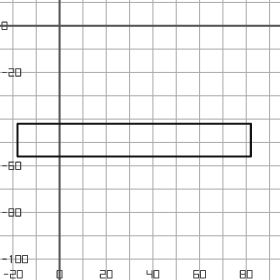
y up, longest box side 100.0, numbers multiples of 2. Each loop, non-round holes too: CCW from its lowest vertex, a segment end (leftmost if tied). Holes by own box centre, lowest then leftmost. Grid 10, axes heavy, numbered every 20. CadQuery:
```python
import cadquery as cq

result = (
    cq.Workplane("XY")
    .moveTo(-18.0, -56.0)
    .lineTo(82.0, -56.0)
    .lineTo(82.0, -42.0)
    .lineTo(-18.0, -42.0)
    .close()
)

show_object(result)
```